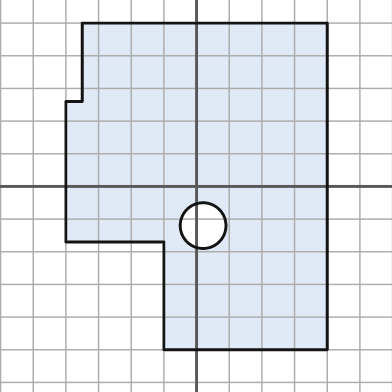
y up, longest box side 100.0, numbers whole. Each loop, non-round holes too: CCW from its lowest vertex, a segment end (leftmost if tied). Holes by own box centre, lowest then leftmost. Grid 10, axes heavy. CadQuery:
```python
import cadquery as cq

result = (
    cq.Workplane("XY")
    .moveTo(-10.0, -50.0)
    .lineTo(40.0, -50.0)
    .lineTo(40.0, 50.0)
    .lineTo(-35.0, 50.0)
    .lineTo(-35.0, 26.0)
    .lineTo(-40.0, 26.0)
    .lineTo(-40.0, -17.0)
    .lineTo(-10.0, -17.0)
    .close()
    .moveTo(2.0, -12.0)
    .circle(7.0)
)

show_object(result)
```